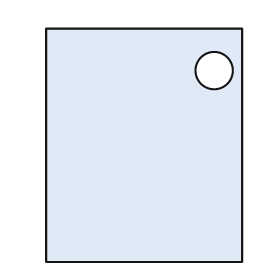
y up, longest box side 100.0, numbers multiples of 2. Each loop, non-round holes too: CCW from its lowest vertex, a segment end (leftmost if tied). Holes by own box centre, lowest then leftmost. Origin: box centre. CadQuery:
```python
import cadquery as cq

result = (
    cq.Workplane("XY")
    .moveTo(-42.0, -50.0)
    .lineTo(42.0, -50.0)
    .lineTo(42.0, 50.0)
    .lineTo(-42.0, 50.0)
    .close()
    .moveTo(30.0, 32.0)
    .circle(8.0)
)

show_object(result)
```